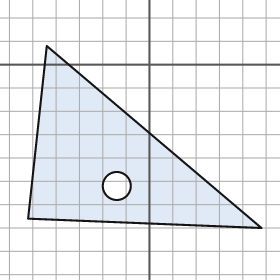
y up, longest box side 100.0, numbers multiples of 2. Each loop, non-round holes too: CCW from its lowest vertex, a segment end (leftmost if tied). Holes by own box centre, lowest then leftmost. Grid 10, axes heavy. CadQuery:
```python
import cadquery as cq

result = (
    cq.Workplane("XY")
    .moveTo(48.0, -70.0)
    .lineTo(-44.0, 8.0)
    .lineTo(-52.0, -66.0)
    .close()
    .moveTo(-14.0, -52.0)
    .circle(6.0)
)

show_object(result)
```